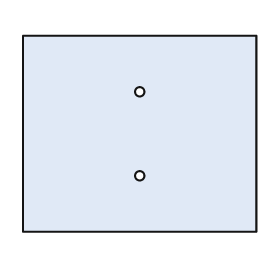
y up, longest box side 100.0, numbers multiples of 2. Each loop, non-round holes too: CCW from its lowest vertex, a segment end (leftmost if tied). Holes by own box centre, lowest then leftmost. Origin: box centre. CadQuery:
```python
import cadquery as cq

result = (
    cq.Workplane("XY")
    .moveTo(-50.0, -42.0)
    .lineTo(50.0, -42.0)
    .lineTo(50.0, 42.0)
    .lineTo(-50.0, 42.0)
    .close()
    .moveTo(0.0, -18.0)
    .circle(2.0)
    .moveTo(0.0, 18.0)
    .circle(2.0)
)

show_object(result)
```